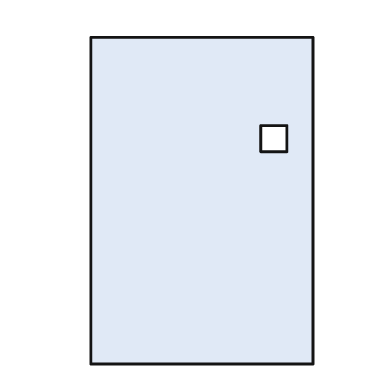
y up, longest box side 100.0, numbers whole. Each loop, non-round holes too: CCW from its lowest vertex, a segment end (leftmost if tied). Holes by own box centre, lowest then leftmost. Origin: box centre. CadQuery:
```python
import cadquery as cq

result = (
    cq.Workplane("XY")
    .moveTo(-34.0, -50.0)
    .lineTo(34.0, -50.0)
    .lineTo(34.0, 50.0)
    .lineTo(-34.0, 50.0)
    .close()
    .moveTo(18.0, 15.0)
    .lineTo(26.0, 15.0)
    .lineTo(26.0, 23.0)
    .lineTo(18.0, 23.0)
    .close()
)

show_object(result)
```